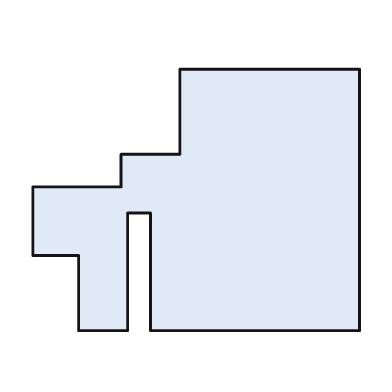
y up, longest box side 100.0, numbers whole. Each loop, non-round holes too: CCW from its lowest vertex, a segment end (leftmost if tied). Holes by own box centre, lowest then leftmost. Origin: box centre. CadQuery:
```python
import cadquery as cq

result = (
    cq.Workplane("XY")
    .moveTo(-36.0, -40.0)
    .lineTo(-21.0, -40.0)
    .lineTo(-21.0, -4.0)
    .lineTo(-14.0, -4.0)
    .lineTo(-14.0, -40.0)
    .lineTo(50.0, -40.0)
    .lineTo(50.0, 40.0)
    .lineTo(-5.0, 40.0)
    .lineTo(-5.0, 14.0)
    .lineTo(-23.0, 14.0)
    .lineTo(-23.0, 4.0)
    .lineTo(-50.0, 4.0)
    .lineTo(-50.0, -17.0)
    .lineTo(-36.0, -17.0)
    .close()
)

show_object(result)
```